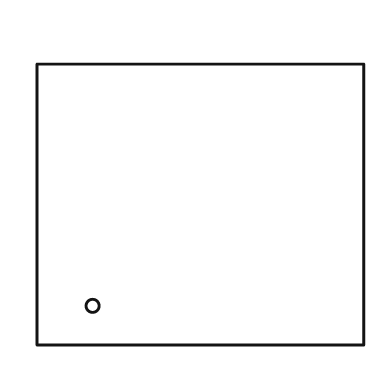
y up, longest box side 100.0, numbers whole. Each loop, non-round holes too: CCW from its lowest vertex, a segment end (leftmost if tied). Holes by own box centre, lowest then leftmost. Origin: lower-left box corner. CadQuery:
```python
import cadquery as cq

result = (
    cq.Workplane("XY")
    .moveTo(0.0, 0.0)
    .lineTo(100.0, 0.0)
    .lineTo(100.0, 86.0)
    .lineTo(0.0, 86.0)
    .close()
    .moveTo(17.0, 12.0)
    .circle(2.0)
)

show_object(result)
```